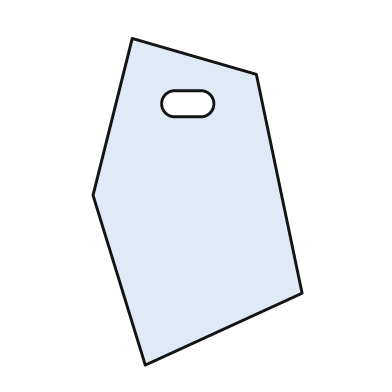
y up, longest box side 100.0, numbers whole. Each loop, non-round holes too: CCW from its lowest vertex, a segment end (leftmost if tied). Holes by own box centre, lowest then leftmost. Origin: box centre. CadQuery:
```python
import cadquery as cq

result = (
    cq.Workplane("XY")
    .moveTo(-16.0, -50.0)
    .lineTo(32.0, -28.0)
    .lineTo(18.0, 39.0)
    .lineTo(-20.0, 50.0)
    .lineTo(-32.0, 2.0)
    .close()
    .moveTo(-7.0, 26.0)
    .lineTo(1.0, 26.0)
    .threePointArc((5.0, 30.0), (1.0, 34.0))
    .lineTo(-7.0, 34.0)
    .threePointArc((-11.0, 30.0), (-7.0, 26.0))
    .close()
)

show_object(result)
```